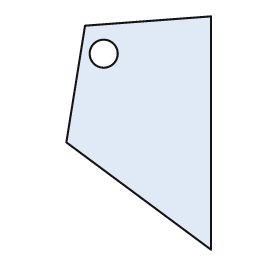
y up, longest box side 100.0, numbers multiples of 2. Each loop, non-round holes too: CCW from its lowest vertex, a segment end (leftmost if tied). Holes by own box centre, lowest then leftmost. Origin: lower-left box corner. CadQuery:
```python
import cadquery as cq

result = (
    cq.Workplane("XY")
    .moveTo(62.0, 0.0)
    .lineTo(62.0, 100.0)
    .lineTo(8.0, 96.0)
    .lineTo(0.0, 46.0)
    .close()
    .moveTo(16.0, 84.0)
    .circle(6.0)
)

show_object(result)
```